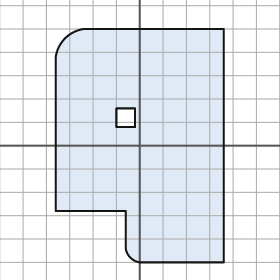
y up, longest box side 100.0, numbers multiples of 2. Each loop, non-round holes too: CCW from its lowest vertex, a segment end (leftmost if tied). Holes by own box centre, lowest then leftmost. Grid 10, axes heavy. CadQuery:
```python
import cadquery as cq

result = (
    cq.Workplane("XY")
    .moveTo(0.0, -50.0)
    .lineTo(36.0, -50.0)
    .lineTo(36.0, 50.0)
    .lineTo(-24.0, 50.0)
    .threePointArc((-32.0, 46.0), (-36.0, 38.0))
    .lineTo(-36.0, -28.0)
    .lineTo(-6.0, -28.0)
    .lineTo(-6.0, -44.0)
    .threePointArc((-4.0, -48.0), (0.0, -50.0))
    .close()
    .moveTo(-10.0, 8.0)
    .lineTo(-2.0, 8.0)
    .lineTo(-2.0, 16.0)
    .lineTo(-10.0, 16.0)
    .close()
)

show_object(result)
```